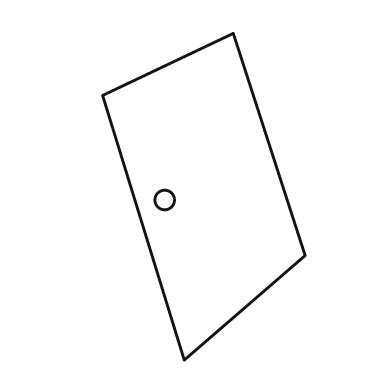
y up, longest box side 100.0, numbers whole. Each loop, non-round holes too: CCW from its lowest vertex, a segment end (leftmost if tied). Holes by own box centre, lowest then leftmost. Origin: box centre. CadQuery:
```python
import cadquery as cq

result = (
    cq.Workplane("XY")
    .moveTo(-6.0, -50.0)
    .lineTo(31.0, -18.0)
    .lineTo(9.0, 50.0)
    .lineTo(-31.0, 31.0)
    .close()
    .moveTo(-12.0, -1.0)
    .circle(3.0)
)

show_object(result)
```